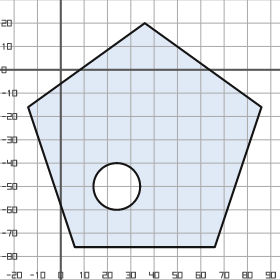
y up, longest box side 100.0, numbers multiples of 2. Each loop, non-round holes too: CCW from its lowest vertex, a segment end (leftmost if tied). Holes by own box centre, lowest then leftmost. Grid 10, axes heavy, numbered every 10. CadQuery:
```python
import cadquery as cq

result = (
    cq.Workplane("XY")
    .moveTo(6.0, -76.0)
    .lineTo(66.0, -76.0)
    .lineTo(86.0, -16.0)
    .lineTo(36.0, 20.0)
    .lineTo(-14.0, -16.0)
    .close()
    .moveTo(24.0, -50.0)
    .circle(10.0)
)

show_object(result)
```